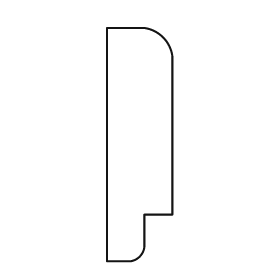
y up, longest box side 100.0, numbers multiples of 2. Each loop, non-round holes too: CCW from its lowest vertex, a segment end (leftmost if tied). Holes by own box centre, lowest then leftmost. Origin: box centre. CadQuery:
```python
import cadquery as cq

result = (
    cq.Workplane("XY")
    .moveTo(-14.0, -50.0)
    .lineTo(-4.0, -50.0)
    .threePointArc((0.0, -48.0), (2.0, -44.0))
    .lineTo(2.0, -30.0)
    .lineTo(14.0, -30.0)
    .lineTo(14.0, 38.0)
    .threePointArc((10.0, 46.0), (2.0, 50.0))
    .lineTo(-14.0, 50.0)
    .close()
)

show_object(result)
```